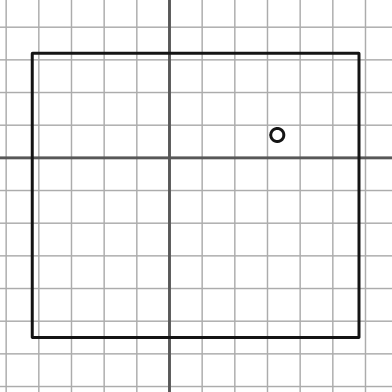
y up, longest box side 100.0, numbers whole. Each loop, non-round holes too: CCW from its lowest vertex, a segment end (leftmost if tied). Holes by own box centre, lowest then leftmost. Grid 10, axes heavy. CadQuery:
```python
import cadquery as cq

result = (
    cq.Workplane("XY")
    .moveTo(-42.0, -55.0)
    .lineTo(58.0, -55.0)
    .lineTo(58.0, 32.0)
    .lineTo(-42.0, 32.0)
    .close()
    .moveTo(33.0, 7.0)
    .circle(2.0)
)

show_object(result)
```